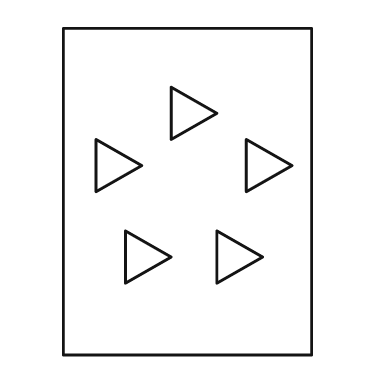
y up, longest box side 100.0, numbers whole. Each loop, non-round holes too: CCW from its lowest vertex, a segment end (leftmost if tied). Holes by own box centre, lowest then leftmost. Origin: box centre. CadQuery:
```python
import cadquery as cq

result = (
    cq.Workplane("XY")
    .moveTo(-38.0, -50.0)
    .lineTo(38.0, -50.0)
    .lineTo(38.0, 50.0)
    .lineTo(-38.0, 50.0)
    .close()
    .moveTo(-19.0, -28.0)
    .lineTo(-5.0, -20.0)
    .lineTo(-19.0, -12.0)
    .close()
    .moveTo(9.0, -28.0)
    .lineTo(23.0, -20.0)
    .lineTo(9.0, -12.0)
    .close()
    .moveTo(-28.0, 0.0)
    .lineTo(-14.0, 8.0)
    .lineTo(-28.0, 16.0)
    .close()
    .moveTo(18.0, 0.0)
    .lineTo(32.0, 8.0)
    .lineTo(18.0, 16.0)
    .close()
    .moveTo(-5.0, 16.0)
    .lineTo(9.0, 24.0)
    .lineTo(-5.0, 32.0)
    .close()
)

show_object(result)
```